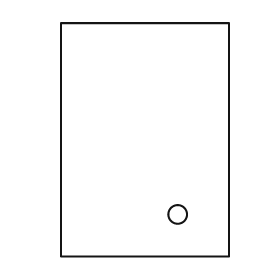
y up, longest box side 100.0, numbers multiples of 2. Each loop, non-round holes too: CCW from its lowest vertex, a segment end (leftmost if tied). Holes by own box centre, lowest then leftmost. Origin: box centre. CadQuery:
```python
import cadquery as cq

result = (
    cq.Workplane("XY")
    .moveTo(-36.0, -50.0)
    .lineTo(36.0, -50.0)
    .lineTo(36.0, 50.0)
    .lineTo(-36.0, 50.0)
    .close()
    .moveTo(14.0, -32.0)
    .circle(4.0)
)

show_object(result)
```